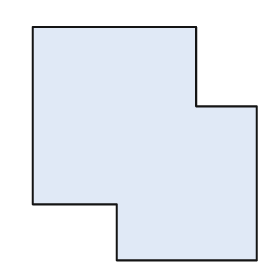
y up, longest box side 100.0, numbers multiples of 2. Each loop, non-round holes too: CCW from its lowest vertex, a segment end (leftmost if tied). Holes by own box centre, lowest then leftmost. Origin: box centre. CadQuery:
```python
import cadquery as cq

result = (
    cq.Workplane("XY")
    .moveTo(-12.0, -50.0)
    .lineTo(48.0, -50.0)
    .lineTo(48.0, 16.0)
    .lineTo(22.0, 16.0)
    .lineTo(22.0, 50.0)
    .lineTo(-48.0, 50.0)
    .lineTo(-48.0, -26.0)
    .lineTo(-12.0, -26.0)
    .close()
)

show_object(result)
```